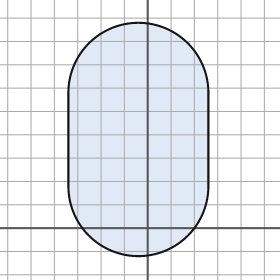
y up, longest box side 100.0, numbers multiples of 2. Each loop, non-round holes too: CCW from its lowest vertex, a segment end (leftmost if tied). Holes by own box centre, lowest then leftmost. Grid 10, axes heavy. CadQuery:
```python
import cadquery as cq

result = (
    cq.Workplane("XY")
    .moveTo(-34.0, 18.0)
    .threePointArc((-4.0, -12.0), (26.0, 18.0))
    .lineTo(26.0, 58.0)
    .threePointArc((-4.0, 88.0), (-34.0, 58.0))
    .close()
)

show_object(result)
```